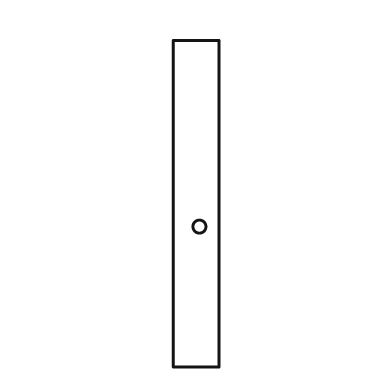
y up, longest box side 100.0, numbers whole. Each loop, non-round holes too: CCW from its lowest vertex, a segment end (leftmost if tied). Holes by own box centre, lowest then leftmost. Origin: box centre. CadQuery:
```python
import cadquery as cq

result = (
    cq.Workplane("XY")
    .moveTo(-7.0, -50.0)
    .lineTo(7.0, -50.0)
    .lineTo(7.0, 50.0)
    .lineTo(-7.0, 50.0)
    .close()
    .moveTo(1.0, -7.0)
    .circle(2.0)
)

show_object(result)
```